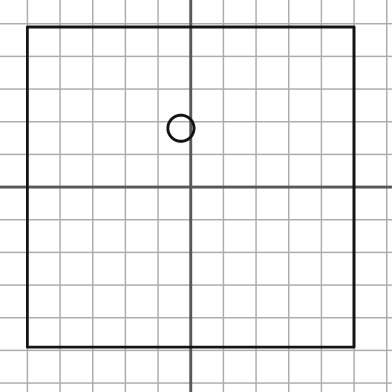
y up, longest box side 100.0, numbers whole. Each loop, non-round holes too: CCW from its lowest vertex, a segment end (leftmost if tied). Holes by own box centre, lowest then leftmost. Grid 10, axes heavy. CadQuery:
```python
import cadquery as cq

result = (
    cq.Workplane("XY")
    .moveTo(-50.0, -49.0)
    .lineTo(50.0, -49.0)
    .lineTo(50.0, 49.0)
    .lineTo(-50.0, 49.0)
    .close()
    .moveTo(-3.0, 18.0)
    .circle(4.0)
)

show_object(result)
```